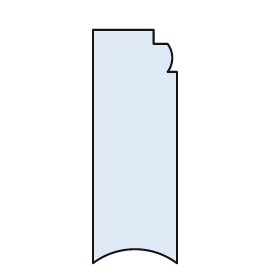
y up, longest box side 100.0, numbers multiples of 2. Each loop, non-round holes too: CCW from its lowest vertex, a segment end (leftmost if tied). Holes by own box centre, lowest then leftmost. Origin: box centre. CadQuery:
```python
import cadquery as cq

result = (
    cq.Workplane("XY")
    .moveTo(-18.0, -50.0)
    .threePointArc((0.0, -44.0), (18.0, -50.0))
    .lineTo(18.0, 32.0)
    .lineTo(14.0, 32.0)
    .threePointArc((16.0, 38.0), (14.0, 44.0))
    .lineTo(8.0, 44.0)
    .lineTo(8.0, 50.0)
    .lineTo(-18.0, 50.0)
    .close()
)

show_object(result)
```